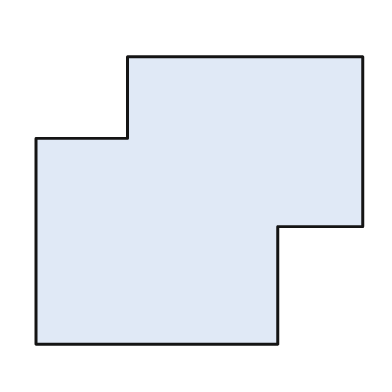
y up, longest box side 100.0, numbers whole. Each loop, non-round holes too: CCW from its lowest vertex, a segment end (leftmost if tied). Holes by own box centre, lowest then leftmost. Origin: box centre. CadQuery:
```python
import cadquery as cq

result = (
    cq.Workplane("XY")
    .moveTo(-50.0, -44.0)
    .lineTo(24.0, -44.0)
    .lineTo(24.0, -8.0)
    .lineTo(50.0, -8.0)
    .lineTo(50.0, 44.0)
    .lineTo(-22.0, 44.0)
    .lineTo(-22.0, 19.0)
    .lineTo(-50.0, 19.0)
    .close()
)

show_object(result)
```